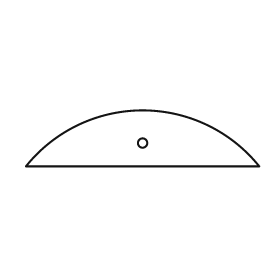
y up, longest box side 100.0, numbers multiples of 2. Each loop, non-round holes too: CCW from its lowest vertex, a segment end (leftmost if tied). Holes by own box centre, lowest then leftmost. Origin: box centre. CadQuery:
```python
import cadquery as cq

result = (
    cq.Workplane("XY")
    .moveTo(-50.0, -12.0)
    .lineTo(50.0, -12.0)
    .threePointArc((0.0, 12.0), (-50.0, -12.0))
    .close()
    .moveTo(0.0, -2.0)
    .circle(2.0)
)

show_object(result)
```